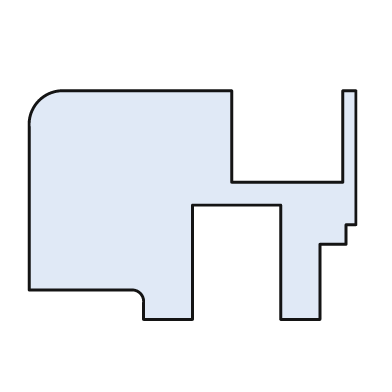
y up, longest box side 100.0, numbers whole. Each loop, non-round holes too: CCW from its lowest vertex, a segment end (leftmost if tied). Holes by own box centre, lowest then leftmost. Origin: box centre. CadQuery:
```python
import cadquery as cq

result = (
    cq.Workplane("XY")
    .moveTo(-15.0, -35.0)
    .lineTo(0.0, -35.0)
    .lineTo(0.0, 0.0)
    .lineTo(27.0, 0.0)
    .lineTo(27.0, -35.0)
    .lineTo(39.0, -35.0)
    .lineTo(39.0, -12.0)
    .lineTo(47.0, -12.0)
    .lineTo(47.0, -6.0)
    .lineTo(50.0, -6.0)
    .lineTo(50.0, 35.0)
    .lineTo(46.0, 35.0)
    .lineTo(46.0, 7.0)
    .lineTo(12.0, 7.0)
    .lineTo(12.0, 35.0)
    .lineTo(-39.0, 35.0)
    .threePointArc((-47.0, 32.0), (-50.0, 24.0))
    .lineTo(-50.0, -26.0)
    .lineTo(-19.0, -26.0)
    .threePointArc((-16.0, -27.0), (-15.0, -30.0))
    .close()
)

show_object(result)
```